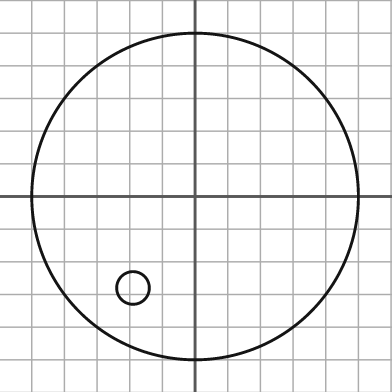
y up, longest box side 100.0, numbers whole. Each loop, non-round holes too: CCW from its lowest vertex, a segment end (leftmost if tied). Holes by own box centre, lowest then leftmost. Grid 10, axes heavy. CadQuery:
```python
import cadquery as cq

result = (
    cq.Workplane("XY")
    .moveTo(0.0, 0.0)
    .circle(50.0)
    .moveTo(-19.0, -28.0)
    .circle(5.0)
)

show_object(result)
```